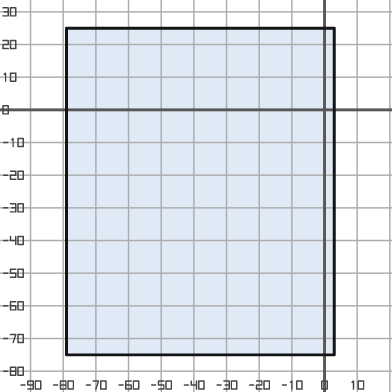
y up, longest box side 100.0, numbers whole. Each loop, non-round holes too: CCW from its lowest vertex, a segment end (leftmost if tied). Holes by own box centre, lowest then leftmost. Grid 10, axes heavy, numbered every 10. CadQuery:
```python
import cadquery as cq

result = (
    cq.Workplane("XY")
    .moveTo(-79.0, -75.0)
    .lineTo(3.0, -75.0)
    .lineTo(3.0, 25.0)
    .lineTo(-79.0, 25.0)
    .close()
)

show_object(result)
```